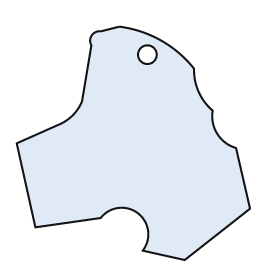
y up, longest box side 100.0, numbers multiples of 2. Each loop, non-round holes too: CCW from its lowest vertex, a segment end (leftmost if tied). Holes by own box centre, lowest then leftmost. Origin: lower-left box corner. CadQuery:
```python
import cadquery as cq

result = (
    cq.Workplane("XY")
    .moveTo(72.0, 0.0)
    .lineTo(100.0, 22.0)
    .lineTo(94.0, 48.0)
    .threePointArc((86.0, 54.0), (84.0, 64.0))
    .threePointArc((78.0, 72.0), (76.0, 82.0))
    .threePointArc((62.0, 94.0), (44.0, 100.0))
    .lineTo(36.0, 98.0)
    .threePointArc((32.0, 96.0), (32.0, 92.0))
    .lineTo(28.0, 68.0)
    .threePointArc((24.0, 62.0), (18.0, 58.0))
    .lineTo(0.0, 50.0)
    .lineTo(8.0, 14.0)
    .lineTo(36.0, 18.0)
    .threePointArc((52.0, 20.0), (54.0, 4.0))
    .close()
    .moveTo(56.0, 88.0)
    .circle(4.0)
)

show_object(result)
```